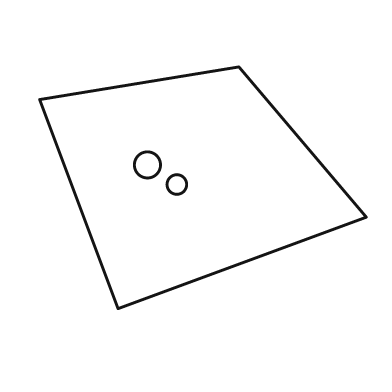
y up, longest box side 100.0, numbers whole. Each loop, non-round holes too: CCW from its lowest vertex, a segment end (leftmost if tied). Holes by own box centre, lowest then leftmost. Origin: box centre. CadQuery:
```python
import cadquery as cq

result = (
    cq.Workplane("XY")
    .moveTo(-26.0, -37.0)
    .lineTo(50.0, -9.0)
    .lineTo(11.0, 37.0)
    .lineTo(-50.0, 27.0)
    .close()
    .moveTo(-8.0, 1.0)
    .circle(3.0)
    .moveTo(-17.0, 7.0)
    .circle(4.0)
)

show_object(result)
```